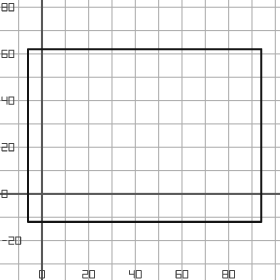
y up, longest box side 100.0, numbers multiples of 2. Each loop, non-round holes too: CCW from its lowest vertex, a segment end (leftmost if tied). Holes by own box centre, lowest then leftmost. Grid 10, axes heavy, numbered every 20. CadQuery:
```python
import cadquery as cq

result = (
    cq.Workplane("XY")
    .moveTo(-6.0, -12.0)
    .lineTo(94.0, -12.0)
    .lineTo(94.0, 62.0)
    .lineTo(-6.0, 62.0)
    .close()
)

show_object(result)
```